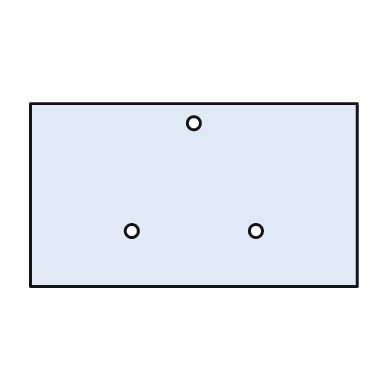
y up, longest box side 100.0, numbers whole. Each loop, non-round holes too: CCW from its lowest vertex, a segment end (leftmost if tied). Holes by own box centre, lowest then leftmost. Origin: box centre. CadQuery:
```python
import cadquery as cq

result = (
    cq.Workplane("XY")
    .moveTo(-50.0, -28.0)
    .lineTo(50.0, -28.0)
    .lineTo(50.0, 28.0)
    .lineTo(-50.0, 28.0)
    .close()
    .moveTo(-19.0, -11.0)
    .circle(2.0)
    .moveTo(19.0, -11.0)
    .circle(2.0)
    .moveTo(0.0, 22.0)
    .circle(2.0)
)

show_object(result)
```